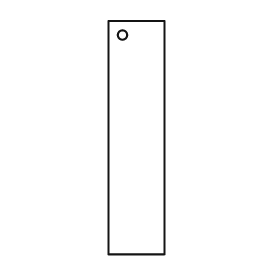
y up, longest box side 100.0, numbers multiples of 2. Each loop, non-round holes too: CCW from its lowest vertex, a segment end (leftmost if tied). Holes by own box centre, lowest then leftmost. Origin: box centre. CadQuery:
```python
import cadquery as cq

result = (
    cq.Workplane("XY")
    .moveTo(-12.0, -50.0)
    .lineTo(12.0, -50.0)
    .lineTo(12.0, 50.0)
    .lineTo(-12.0, 50.0)
    .close()
    .moveTo(-6.0, 44.0)
    .circle(2.0)
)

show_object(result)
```